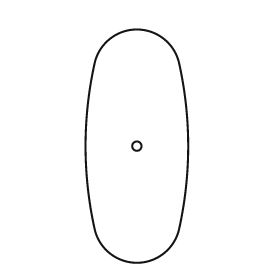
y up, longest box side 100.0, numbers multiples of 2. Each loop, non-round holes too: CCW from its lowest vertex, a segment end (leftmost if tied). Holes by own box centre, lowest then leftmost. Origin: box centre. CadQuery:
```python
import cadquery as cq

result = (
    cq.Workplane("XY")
    .moveTo(-18.0, -36.0)
    .threePointArc((0.0, -50.0), (18.0, -36.0))
    .threePointArc((22.0, 0.0), (18.0, 36.0))
    .threePointArc((0.0, 50.0), (-18.0, 36.0))
    .threePointArc((-22.0, 0.0), (-18.0, -36.0))
    .close()
    .moveTo(0.0, 0.0)
    .circle(2.0)
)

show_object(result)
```